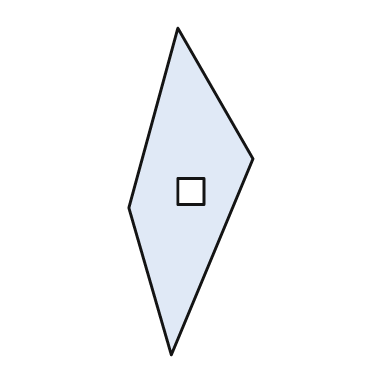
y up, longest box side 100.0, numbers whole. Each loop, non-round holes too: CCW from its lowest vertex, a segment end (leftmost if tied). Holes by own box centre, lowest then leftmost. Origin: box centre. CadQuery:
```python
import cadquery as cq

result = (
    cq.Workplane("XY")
    .moveTo(-6.0, -50.0)
    .lineTo(19.0, 10.0)
    .lineTo(-4.0, 50.0)
    .lineTo(-19.0, -5.0)
    .close()
    .moveTo(-4.0, -4.0)
    .lineTo(4.0, -4.0)
    .lineTo(4.0, 4.0)
    .lineTo(-4.0, 4.0)
    .close()
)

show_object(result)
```